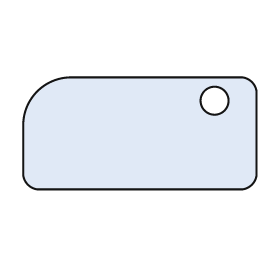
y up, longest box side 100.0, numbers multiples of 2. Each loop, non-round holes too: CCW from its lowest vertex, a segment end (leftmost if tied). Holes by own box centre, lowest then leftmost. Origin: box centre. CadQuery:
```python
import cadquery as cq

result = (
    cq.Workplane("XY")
    .moveTo(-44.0, -24.0)
    .lineTo(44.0, -24.0)
    .threePointArc((48.0, -22.0), (50.0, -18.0))
    .lineTo(50.0, 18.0)
    .threePointArc((48.0, 22.0), (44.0, 24.0))
    .lineTo(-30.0, 24.0)
    .threePointArc((-44.0, 18.0), (-50.0, 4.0))
    .lineTo(-50.0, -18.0)
    .threePointArc((-48.0, -22.0), (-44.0, -24.0))
    .close()
    .moveTo(32.0, 14.0)
    .circle(6.0)
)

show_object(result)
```